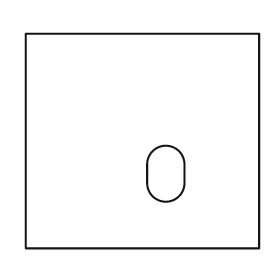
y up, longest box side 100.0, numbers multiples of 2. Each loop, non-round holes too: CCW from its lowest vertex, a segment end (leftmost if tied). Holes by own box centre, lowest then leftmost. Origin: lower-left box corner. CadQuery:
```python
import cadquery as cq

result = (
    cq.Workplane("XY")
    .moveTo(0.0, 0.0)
    .lineTo(100.0, 0.0)
    .lineTo(100.0, 92.0)
    .lineTo(0.0, 92.0)
    .close()
    .moveTo(52.0, 28.0)
    .threePointArc((60.0, 20.0), (68.0, 28.0))
    .lineTo(68.0, 36.0)
    .threePointArc((60.0, 44.0), (52.0, 36.0))
    .close()
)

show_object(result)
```